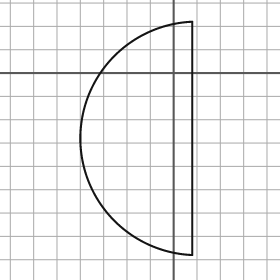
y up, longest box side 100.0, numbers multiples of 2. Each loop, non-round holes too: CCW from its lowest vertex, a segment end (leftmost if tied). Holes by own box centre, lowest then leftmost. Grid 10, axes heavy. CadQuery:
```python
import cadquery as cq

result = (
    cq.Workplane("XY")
    .moveTo(8.0, -78.0)
    .lineTo(8.0, 22.0)
    .threePointArc((-40.0, -28.0), (8.0, -78.0))
    .close()
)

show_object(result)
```